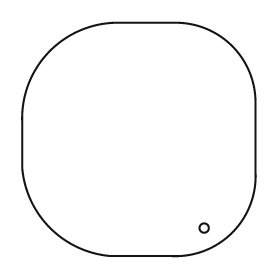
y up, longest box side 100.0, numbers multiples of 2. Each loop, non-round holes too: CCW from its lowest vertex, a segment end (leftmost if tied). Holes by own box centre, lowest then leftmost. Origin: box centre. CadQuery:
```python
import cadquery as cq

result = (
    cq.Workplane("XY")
    .moveTo(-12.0, -50.0)
    .lineTo(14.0, -50.0)
    .threePointArc((40.0, -40.0), (50.0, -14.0))
    .lineTo(50.0, 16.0)
    .threePointArc((40.0, 40.0), (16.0, 50.0))
    .lineTo(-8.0, 50.0)
    .threePointArc((-38.0, 38.0), (-50.0, 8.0))
    .lineTo(-50.0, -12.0)
    .threePointArc((-38.0, -38.0), (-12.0, -50.0))
    .close()
    .moveTo(28.0, -38.0)
    .circle(2.0)
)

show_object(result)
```